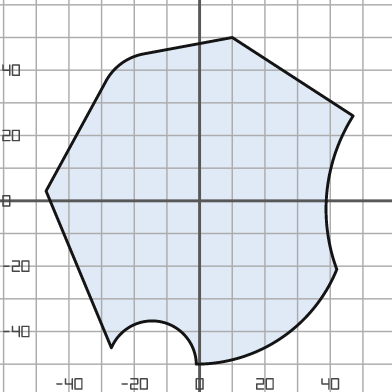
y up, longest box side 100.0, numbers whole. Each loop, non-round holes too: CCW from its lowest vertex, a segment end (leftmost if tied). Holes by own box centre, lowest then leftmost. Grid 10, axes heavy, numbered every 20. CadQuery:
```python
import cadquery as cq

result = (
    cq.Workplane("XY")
    .moveTo(-1.0, -50.0)
    .threePointArc((25.0, -42.0), (42.0, -21.0))
    .threePointArc((39.0, 3.0), (47.0, 26.0))
    .lineTo(10.0, 50.0)
    .lineTo(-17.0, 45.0)
    .threePointArc((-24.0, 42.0), (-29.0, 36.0))
    .lineTo(-47.0, 3.0)
    .lineTo(-27.0, -45.0)
    .threePointArc((-12.0, -37.0), (-1.0, -50.0))
    .close()
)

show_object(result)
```